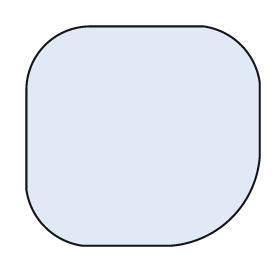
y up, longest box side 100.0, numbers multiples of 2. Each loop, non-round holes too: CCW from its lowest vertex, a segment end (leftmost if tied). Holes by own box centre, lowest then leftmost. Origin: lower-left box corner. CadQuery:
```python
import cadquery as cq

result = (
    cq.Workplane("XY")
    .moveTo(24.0, 0.0)
    .lineTo(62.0, 0.0)
    .threePointArc((88.0, 12.0), (100.0, 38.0))
    .lineTo(100.0, 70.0)
    .threePointArc((92.0, 86.0), (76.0, 94.0))
    .lineTo(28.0, 94.0)
    .threePointArc((8.0, 86.0), (0.0, 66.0))
    .lineTo(0.0, 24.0)
    .threePointArc((8.0, 8.0), (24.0, 0.0))
    .close()
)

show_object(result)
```